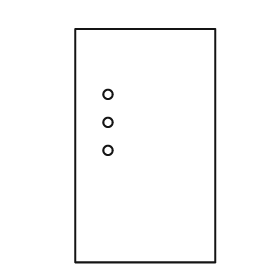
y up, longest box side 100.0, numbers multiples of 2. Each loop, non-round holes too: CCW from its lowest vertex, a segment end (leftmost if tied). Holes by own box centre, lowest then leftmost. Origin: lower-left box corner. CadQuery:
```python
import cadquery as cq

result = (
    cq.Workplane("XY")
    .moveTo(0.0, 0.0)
    .lineTo(60.0, 0.0)
    .lineTo(60.0, 100.0)
    .lineTo(0.0, 100.0)
    .close()
    .moveTo(14.0, 48.0)
    .circle(2.0)
    .moveTo(14.0, 60.0)
    .circle(2.0)
    .moveTo(14.0, 72.0)
    .circle(2.0)
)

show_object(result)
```